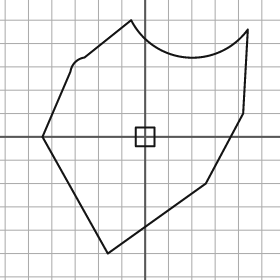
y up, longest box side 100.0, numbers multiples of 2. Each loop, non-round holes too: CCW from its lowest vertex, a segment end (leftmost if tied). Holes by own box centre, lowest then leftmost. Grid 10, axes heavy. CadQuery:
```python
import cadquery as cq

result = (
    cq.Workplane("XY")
    .moveTo(-16.0, -50.0)
    .lineTo(26.0, -20.0)
    .lineTo(42.0, 10.0)
    .lineTo(44.0, 46.0)
    .threePointArc((18.0, 34.0), (-6.0, 50.0))
    .lineTo(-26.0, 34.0)
    .threePointArc((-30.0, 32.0), (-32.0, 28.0))
    .lineTo(-44.0, 0.0)
    .close()
    .moveTo(-4.0, -4.0)
    .lineTo(4.0, -4.0)
    .lineTo(4.0, 4.0)
    .lineTo(-4.0, 4.0)
    .close()
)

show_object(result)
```